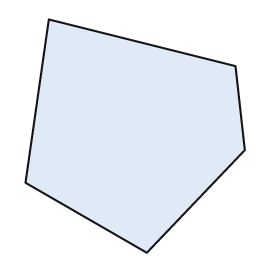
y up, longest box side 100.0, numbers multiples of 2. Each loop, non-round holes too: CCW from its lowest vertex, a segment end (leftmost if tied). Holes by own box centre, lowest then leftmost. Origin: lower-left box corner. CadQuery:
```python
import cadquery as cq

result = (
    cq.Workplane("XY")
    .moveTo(52.0, 0.0)
    .lineTo(94.0, 44.0)
    .lineTo(90.0, 80.0)
    .lineTo(10.0, 100.0)
    .lineTo(0.0, 30.0)
    .close()
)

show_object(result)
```